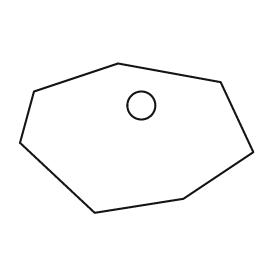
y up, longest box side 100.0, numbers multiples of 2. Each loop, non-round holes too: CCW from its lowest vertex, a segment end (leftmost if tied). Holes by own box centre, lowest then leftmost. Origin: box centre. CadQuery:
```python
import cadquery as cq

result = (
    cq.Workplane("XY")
    .moveTo(-18.0, -32.0)
    .lineTo(20.0, -26.0)
    .lineTo(50.0, -6.0)
    .lineTo(36.0, 24.0)
    .lineTo(-8.0, 32.0)
    .lineTo(-44.0, 20.0)
    .lineTo(-50.0, -2.0)
    .close()
    .moveTo(2.0, 14.0)
    .circle(6.0)
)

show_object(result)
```